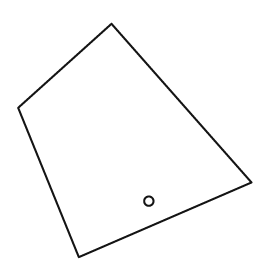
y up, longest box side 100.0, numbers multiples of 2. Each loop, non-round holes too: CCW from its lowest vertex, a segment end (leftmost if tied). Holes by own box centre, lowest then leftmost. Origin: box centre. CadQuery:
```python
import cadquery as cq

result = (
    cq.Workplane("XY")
    .moveTo(-24.0, -50.0)
    .lineTo(50.0, -18.0)
    .lineTo(-10.0, 50.0)
    .lineTo(-50.0, 14.0)
    .close()
    .moveTo(6.0, -26.0)
    .circle(2.0)
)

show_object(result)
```